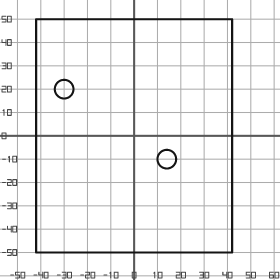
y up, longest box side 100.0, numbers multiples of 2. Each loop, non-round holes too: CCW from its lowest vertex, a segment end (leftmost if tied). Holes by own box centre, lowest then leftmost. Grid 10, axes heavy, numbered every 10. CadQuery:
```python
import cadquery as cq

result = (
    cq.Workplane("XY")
    .moveTo(-42.0, -50.0)
    .lineTo(42.0, -50.0)
    .lineTo(42.0, 50.0)
    .lineTo(-42.0, 50.0)
    .close()
    .moveTo(14.0, -10.0)
    .circle(4.0)
    .moveTo(-30.0, 20.0)
    .circle(4.0)
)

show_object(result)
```